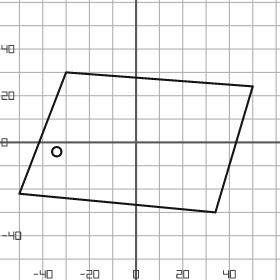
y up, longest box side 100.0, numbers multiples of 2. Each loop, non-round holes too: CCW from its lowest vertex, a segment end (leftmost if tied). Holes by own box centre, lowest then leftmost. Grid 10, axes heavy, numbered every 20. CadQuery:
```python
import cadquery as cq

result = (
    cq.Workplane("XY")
    .moveTo(34.0, -30.0)
    .lineTo(50.0, 24.0)
    .lineTo(-30.0, 30.0)
    .lineTo(-50.0, -22.0)
    .close()
    .moveTo(-34.0, -4.0)
    .circle(2.0)
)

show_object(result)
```